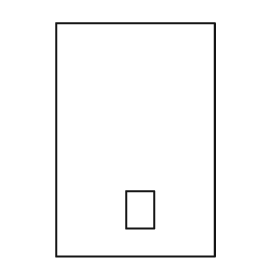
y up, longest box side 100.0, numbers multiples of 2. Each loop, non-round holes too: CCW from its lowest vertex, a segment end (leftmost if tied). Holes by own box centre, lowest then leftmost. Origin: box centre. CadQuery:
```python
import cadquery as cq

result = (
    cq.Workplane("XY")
    .moveTo(-34.0, -50.0)
    .lineTo(34.0, -50.0)
    .lineTo(34.0, 50.0)
    .lineTo(-34.0, 50.0)
    .close()
    .moveTo(-4.0, -38.0)
    .lineTo(8.0, -38.0)
    .lineTo(8.0, -22.0)
    .lineTo(-4.0, -22.0)
    .close()
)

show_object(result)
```